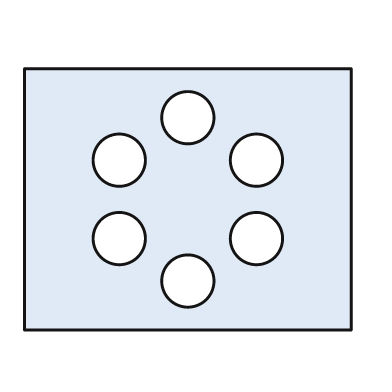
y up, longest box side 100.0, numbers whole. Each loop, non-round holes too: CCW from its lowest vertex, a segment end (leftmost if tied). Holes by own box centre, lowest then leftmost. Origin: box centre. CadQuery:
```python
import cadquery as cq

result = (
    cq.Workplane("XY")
    .moveTo(-50.0, -40.0)
    .lineTo(50.0, -40.0)
    .lineTo(50.0, 40.0)
    .lineTo(-50.0, 40.0)
    .close()
    .moveTo(0.0, -25.0)
    .circle(8.0)
    .moveTo(-21.0, -12.0)
    .circle(8.0)
    .moveTo(21.0, -12.0)
    .circle(8.0)
    .moveTo(-21.0, 12.0)
    .circle(8.0)
    .moveTo(21.0, 12.0)
    .circle(8.0)
    .moveTo(0.0, 25.0)
    .circle(8.0)
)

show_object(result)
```